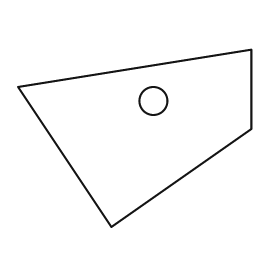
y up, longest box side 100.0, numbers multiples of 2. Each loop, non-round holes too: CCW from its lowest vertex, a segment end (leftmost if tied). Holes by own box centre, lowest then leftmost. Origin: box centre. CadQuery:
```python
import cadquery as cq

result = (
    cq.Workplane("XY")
    .moveTo(-10.0, -38.0)
    .lineTo(50.0, 4.0)
    .lineTo(50.0, 38.0)
    .lineTo(-50.0, 22.0)
    .close()
    .moveTo(8.0, 16.0)
    .circle(6.0)
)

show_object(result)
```